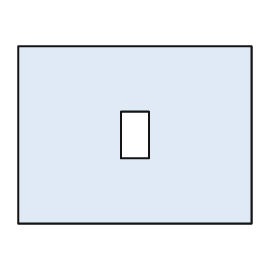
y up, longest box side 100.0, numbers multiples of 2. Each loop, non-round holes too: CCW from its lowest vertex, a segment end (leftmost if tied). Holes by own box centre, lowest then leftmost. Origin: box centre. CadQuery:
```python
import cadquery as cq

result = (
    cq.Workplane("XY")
    .moveTo(-50.0, -38.0)
    .lineTo(50.0, -38.0)
    .lineTo(50.0, 38.0)
    .lineTo(-50.0, 38.0)
    .close()
    .moveTo(-6.0, -10.0)
    .lineTo(6.0, -10.0)
    .lineTo(6.0, 10.0)
    .lineTo(-6.0, 10.0)
    .close()
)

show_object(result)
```